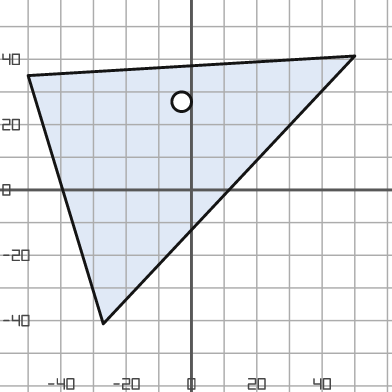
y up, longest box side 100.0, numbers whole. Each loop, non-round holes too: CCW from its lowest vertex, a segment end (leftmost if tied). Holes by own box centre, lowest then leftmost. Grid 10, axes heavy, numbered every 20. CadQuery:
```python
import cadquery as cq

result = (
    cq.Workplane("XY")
    .moveTo(-27.0, -41.0)
    .lineTo(50.0, 41.0)
    .lineTo(-50.0, 35.0)
    .close()
    .moveTo(-3.0, 27.0)
    .circle(3.0)
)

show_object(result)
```